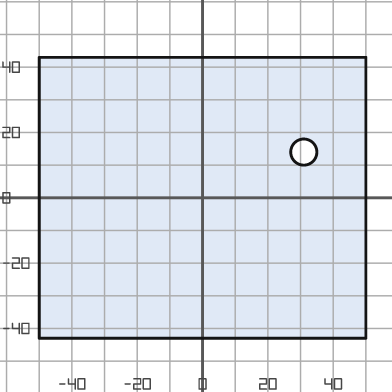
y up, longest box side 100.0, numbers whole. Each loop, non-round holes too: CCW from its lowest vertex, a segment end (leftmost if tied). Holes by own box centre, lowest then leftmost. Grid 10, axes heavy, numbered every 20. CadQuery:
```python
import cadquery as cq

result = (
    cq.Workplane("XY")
    .moveTo(-50.0, -43.0)
    .lineTo(50.0, -43.0)
    .lineTo(50.0, 43.0)
    .lineTo(-50.0, 43.0)
    .close()
    .moveTo(31.0, 14.0)
    .circle(4.0)
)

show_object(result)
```